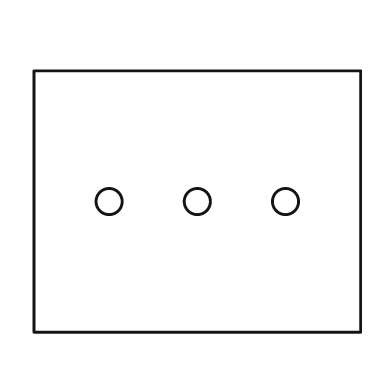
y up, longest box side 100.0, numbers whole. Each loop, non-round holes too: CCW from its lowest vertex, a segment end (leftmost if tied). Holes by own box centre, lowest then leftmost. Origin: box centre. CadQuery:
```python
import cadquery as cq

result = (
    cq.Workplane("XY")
    .moveTo(-50.0, -40.0)
    .lineTo(50.0, -40.0)
    .lineTo(50.0, 40.0)
    .lineTo(-50.0, 40.0)
    .close()
    .moveTo(-27.0, 0.0)
    .circle(4.0)
    .moveTo(0.0, 0.0)
    .circle(4.0)
    .moveTo(27.0, 0.0)
    .circle(4.0)
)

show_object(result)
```